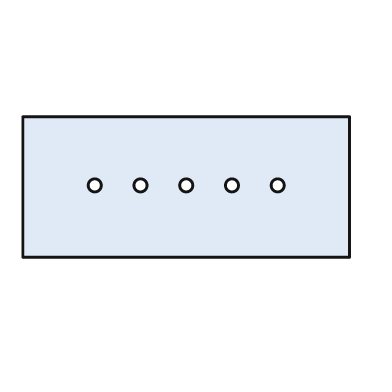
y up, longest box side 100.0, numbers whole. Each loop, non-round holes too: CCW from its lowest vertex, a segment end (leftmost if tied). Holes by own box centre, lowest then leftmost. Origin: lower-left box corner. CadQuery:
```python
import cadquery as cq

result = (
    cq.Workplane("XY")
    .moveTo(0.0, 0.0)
    .lineTo(100.0, 0.0)
    .lineTo(100.0, 43.0)
    .lineTo(0.0, 43.0)
    .close()
    .moveTo(22.0, 22.0)
    .circle(2.0)
    .moveTo(36.0, 22.0)
    .circle(2.0)
    .moveTo(50.0, 22.0)
    .circle(2.0)
    .moveTo(64.0, 22.0)
    .circle(2.0)
    .moveTo(78.0, 22.0)
    .circle(2.0)
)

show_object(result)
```